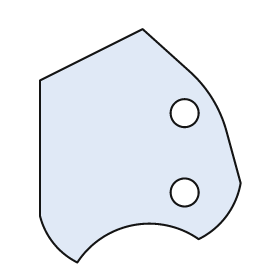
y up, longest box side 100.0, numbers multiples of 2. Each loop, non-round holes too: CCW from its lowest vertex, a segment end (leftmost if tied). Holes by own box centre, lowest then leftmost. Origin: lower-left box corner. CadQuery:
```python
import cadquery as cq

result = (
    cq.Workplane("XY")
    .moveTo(16.0, 0.0)
    .threePointArc((40.0, 16.0), (68.0, 10.0))
    .threePointArc((80.0, 20.0), (86.0, 34.0))
    .lineTo(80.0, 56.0)
    .threePointArc((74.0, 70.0), (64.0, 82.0))
    .lineTo(44.0, 100.0)
    .lineTo(0.0, 78.0)
    .lineTo(0.0, 20.0)
    .threePointArc((6.0, 8.0), (16.0, 0.0))
    .close()
    .moveTo(62.0, 30.0)
    .circle(6.0)
    .moveTo(62.0, 64.0)
    .circle(6.0)
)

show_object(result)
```